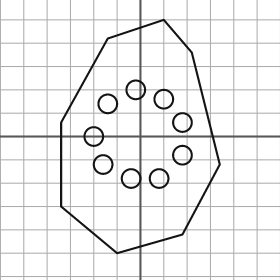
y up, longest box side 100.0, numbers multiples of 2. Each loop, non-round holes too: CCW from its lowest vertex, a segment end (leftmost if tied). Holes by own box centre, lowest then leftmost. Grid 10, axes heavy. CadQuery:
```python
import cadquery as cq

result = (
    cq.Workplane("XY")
    .moveTo(-10.0, -50.0)
    .lineTo(18.0, -42.0)
    .lineTo(34.0, -12.0)
    .lineTo(22.0, 36.0)
    .lineTo(10.0, 50.0)
    .lineTo(-14.0, 42.0)
    .lineTo(-34.0, 6.0)
    .lineTo(-34.0, -30.0)
    .close()
    .moveTo(-4.0, -18.0)
    .circle(4.0)
    .moveTo(8.0, -18.0)
    .circle(4.0)
    .moveTo(-16.0, -12.0)
    .circle(4.0)
    .moveTo(18.0, -8.0)
    .circle(4.0)
    .moveTo(-20.0, 0.0)
    .circle(4.0)
    .moveTo(18.0, 6.0)
    .circle(4.0)
    .moveTo(-14.0, 14.0)
    .circle(4.0)
    .moveTo(10.0, 16.0)
    .circle(4.0)
    .moveTo(-2.0, 20.0)
    .circle(4.0)
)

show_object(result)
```